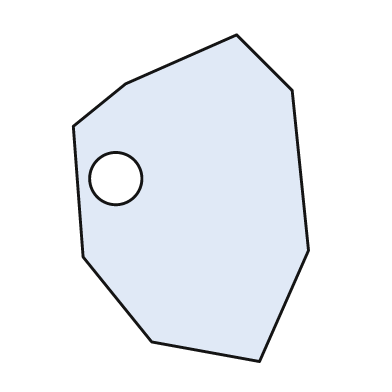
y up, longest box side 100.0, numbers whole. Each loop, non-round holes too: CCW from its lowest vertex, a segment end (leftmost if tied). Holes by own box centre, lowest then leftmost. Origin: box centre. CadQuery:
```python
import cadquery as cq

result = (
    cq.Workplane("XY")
    .moveTo(21.0, -50.0)
    .lineTo(36.0, -16.0)
    .lineTo(31.0, 33.0)
    .lineTo(14.0, 50.0)
    .lineTo(-20.0, 35.0)
    .lineTo(-36.0, 22.0)
    .lineTo(-33.0, -18.0)
    .lineTo(-12.0, -44.0)
    .close()
    .moveTo(-23.0, 6.0)
    .circle(8.0)
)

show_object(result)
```